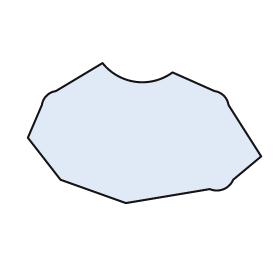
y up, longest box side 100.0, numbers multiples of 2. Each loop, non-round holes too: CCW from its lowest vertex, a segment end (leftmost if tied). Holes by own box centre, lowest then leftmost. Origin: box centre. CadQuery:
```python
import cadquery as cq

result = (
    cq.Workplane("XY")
    .moveTo(-8.0, -30.0)
    .lineTo(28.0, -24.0)
    .threePointArc((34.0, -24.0), (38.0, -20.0))
    .lineTo(50.0, -10.0)
    .lineTo(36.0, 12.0)
    .threePointArc((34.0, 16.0), (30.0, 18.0))
    .lineTo(12.0, 26.0)
    .threePointArc((-4.0, 22.0), (-18.0, 30.0))
    .lineTo(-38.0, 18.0)
    .threePointArc((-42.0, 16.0), (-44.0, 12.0))
    .lineTo(-50.0, -2.0)
    .lineTo(-36.0, -20.0)
    .close()
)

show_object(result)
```